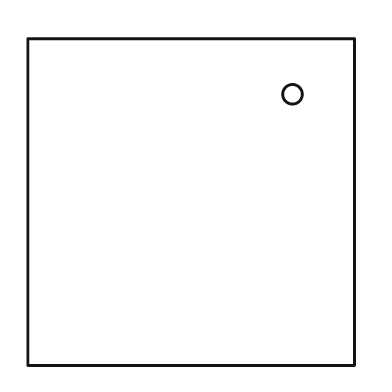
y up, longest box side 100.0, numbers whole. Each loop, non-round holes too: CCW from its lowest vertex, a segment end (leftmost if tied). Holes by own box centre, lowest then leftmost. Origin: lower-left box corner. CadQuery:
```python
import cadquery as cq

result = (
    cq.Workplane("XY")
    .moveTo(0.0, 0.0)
    .lineTo(100.0, 0.0)
    .lineTo(100.0, 100.0)
    .lineTo(0.0, 100.0)
    .close()
    .moveTo(81.0, 83.0)
    .circle(3.0)
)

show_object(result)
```